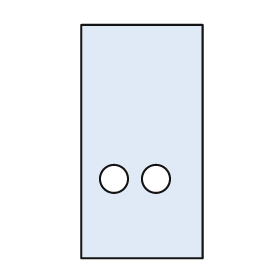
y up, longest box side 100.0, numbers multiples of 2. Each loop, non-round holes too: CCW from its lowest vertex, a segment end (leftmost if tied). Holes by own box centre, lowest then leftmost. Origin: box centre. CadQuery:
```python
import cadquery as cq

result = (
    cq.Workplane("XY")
    .moveTo(-26.0, -50.0)
    .lineTo(26.0, -50.0)
    .lineTo(26.0, 50.0)
    .lineTo(-26.0, 50.0)
    .close()
    .moveTo(-12.0, -16.0)
    .circle(6.0)
    .moveTo(6.0, -16.0)
    .circle(6.0)
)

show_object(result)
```